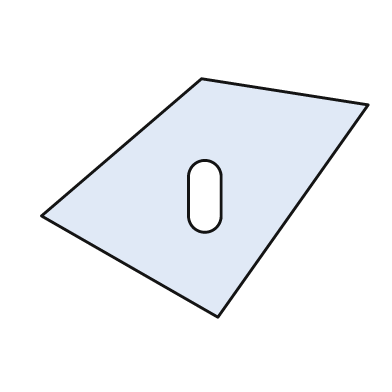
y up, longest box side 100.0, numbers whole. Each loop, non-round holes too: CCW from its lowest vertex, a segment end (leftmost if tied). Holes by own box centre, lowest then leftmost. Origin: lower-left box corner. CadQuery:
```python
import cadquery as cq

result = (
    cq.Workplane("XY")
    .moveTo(54.0, 0.0)
    .lineTo(100.0, 65.0)
    .lineTo(49.0, 73.0)
    .lineTo(0.0, 31.0)
    .close()
    .moveTo(45.0, 31.0)
    .threePointArc((50.0, 26.0), (55.0, 31.0))
    .lineTo(55.0, 43.0)
    .threePointArc((50.0, 48.0), (45.0, 43.0))
    .close()
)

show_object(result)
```